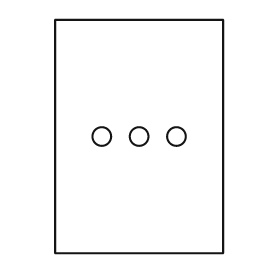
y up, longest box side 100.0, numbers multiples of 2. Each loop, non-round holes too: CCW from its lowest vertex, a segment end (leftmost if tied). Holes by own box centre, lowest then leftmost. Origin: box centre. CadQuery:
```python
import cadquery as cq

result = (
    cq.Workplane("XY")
    .moveTo(-36.0, -50.0)
    .lineTo(36.0, -50.0)
    .lineTo(36.0, 50.0)
    .lineTo(-36.0, 50.0)
    .close()
    .moveTo(-16.0, 0.0)
    .circle(4.0)
    .moveTo(0.0, 0.0)
    .circle(4.0)
    .moveTo(16.0, 0.0)
    .circle(4.0)
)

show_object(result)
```